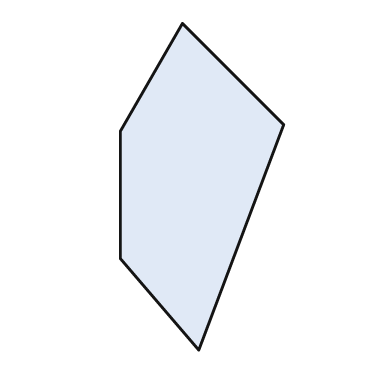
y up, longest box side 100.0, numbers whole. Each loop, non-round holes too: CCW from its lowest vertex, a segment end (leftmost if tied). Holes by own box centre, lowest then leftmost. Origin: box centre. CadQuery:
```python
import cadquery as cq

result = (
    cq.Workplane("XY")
    .moveTo(-1.0, -50.0)
    .lineTo(25.0, 19.0)
    .lineTo(-6.0, 50.0)
    .lineTo(-25.0, 17.0)
    .lineTo(-25.0, -22.0)
    .close()
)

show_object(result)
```